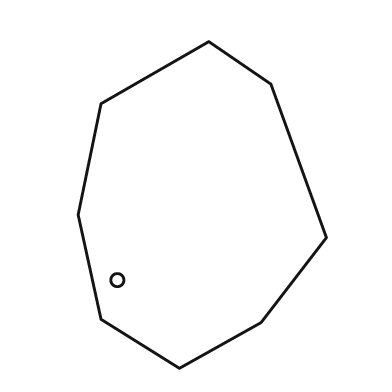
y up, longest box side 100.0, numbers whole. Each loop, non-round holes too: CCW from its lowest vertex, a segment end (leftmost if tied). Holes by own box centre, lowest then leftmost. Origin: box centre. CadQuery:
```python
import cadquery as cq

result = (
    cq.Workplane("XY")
    .moveTo(-7.0, -50.0)
    .lineTo(18.0, -36.0)
    .lineTo(38.0, -10.0)
    .lineTo(21.0, 37.0)
    .lineTo(2.0, 50.0)
    .lineTo(-31.0, 31.0)
    .lineTo(-38.0, -3.0)
    .lineTo(-31.0, -35.0)
    .close()
    .moveTo(-26.0, -23.0)
    .circle(2.0)
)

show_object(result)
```